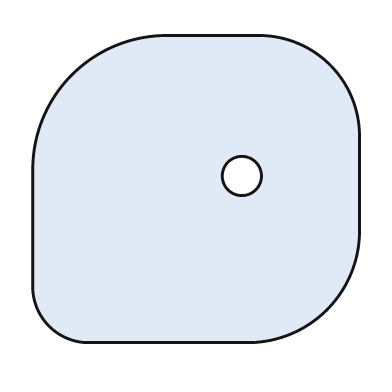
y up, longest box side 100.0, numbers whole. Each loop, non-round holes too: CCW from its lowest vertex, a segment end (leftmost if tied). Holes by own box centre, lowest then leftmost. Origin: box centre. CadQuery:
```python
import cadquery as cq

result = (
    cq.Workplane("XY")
    .moveTo(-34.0, -47.0)
    .lineTo(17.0, -47.0)
    .threePointArc((40.0, -37.0), (50.0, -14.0))
    .lineTo(50.0, 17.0)
    .threePointArc((41.0, 38.0), (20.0, 47.0))
    .lineTo(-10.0, 47.0)
    .threePointArc((-38.0, 35.0), (-50.0, 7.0))
    .lineTo(-50.0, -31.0)
    .threePointArc((-45.0, -42.0), (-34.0, -47.0))
    .close()
    .moveTo(14.0, 4.0)
    .circle(6.0)
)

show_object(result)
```